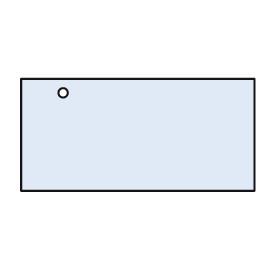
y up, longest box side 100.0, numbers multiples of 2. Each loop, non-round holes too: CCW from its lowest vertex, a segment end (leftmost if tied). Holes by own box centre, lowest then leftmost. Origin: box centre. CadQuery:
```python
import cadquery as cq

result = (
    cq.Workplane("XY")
    .moveTo(-50.0, -24.0)
    .lineTo(50.0, -24.0)
    .lineTo(50.0, 24.0)
    .lineTo(-50.0, 24.0)
    .close()
    .moveTo(-32.0, 18.0)
    .circle(2.0)
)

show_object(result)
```